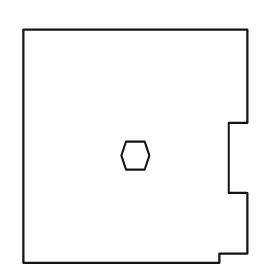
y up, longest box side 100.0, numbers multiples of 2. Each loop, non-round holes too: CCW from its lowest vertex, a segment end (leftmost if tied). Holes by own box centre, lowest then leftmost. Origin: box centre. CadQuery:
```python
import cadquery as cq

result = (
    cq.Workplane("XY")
    .moveTo(-48.0, -50.0)
    .lineTo(36.0, -50.0)
    .lineTo(36.0, -46.0)
    .lineTo(48.0, -46.0)
    .lineTo(48.0, -20.0)
    .lineTo(40.0, -20.0)
    .lineTo(40.0, 10.0)
    .lineTo(48.0, 10.0)
    .lineTo(48.0, 50.0)
    .lineTo(-48.0, 50.0)
    .close()
    .moveTo(-4.0, -10.0)
    .lineTo(4.0, -10.0)
    .lineTo(6.0, -4.0)
    .lineTo(4.0, 2.0)
    .lineTo(-4.0, 2.0)
    .lineTo(-6.0, -4.0)
    .close()
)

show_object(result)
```